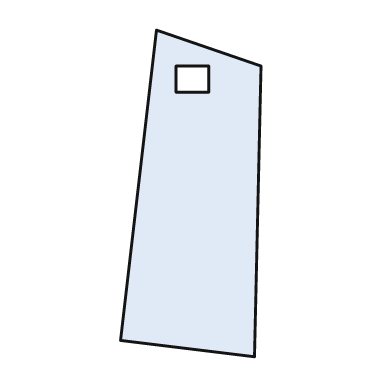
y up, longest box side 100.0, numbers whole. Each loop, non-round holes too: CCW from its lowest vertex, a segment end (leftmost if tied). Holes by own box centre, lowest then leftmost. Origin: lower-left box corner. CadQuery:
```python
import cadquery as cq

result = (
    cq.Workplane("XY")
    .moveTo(41.0, 0.0)
    .lineTo(43.0, 89.0)
    .lineTo(11.0, 100.0)
    .lineTo(0.0, 5.0)
    .close()
    .moveTo(17.0, 81.0)
    .lineTo(27.0, 81.0)
    .lineTo(27.0, 89.0)
    .lineTo(17.0, 89.0)
    .close()
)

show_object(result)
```